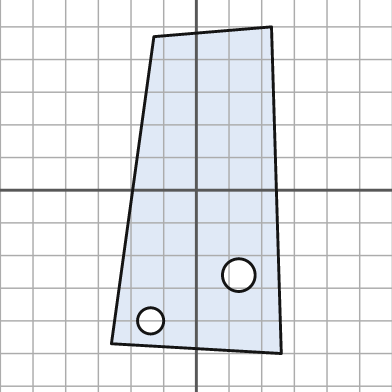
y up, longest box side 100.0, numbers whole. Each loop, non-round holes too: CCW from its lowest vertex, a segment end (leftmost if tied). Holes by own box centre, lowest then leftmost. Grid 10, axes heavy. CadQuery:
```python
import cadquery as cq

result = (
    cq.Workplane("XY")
    .moveTo(26.0, -50.0)
    .lineTo(23.0, 50.0)
    .lineTo(-13.0, 47.0)
    .lineTo(-26.0, -47.0)
    .close()
    .moveTo(-14.0, -40.0)
    .circle(4.0)
    .moveTo(13.0, -26.0)
    .circle(5.0)
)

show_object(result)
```